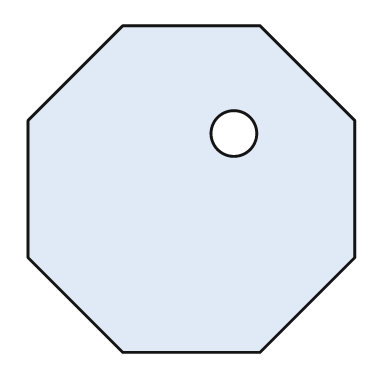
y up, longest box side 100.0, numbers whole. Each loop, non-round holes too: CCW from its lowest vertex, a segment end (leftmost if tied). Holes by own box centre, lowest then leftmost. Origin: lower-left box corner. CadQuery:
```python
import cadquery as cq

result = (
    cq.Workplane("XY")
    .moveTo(29.0, 0.0)
    .lineTo(71.0, 0.0)
    .lineTo(100.0, 29.0)
    .lineTo(100.0, 71.0)
    .lineTo(71.0, 100.0)
    .lineTo(29.0, 100.0)
    .lineTo(0.0, 71.0)
    .lineTo(0.0, 29.0)
    .close()
    .moveTo(63.0, 67.0)
    .circle(7.0)
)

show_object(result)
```